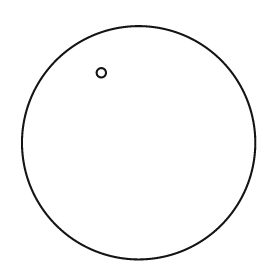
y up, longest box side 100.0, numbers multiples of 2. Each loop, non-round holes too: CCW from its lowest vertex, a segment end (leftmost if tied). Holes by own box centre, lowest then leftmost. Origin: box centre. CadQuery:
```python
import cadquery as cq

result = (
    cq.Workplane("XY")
    .moveTo(0.0, 0.0)
    .circle(50.0)
    .moveTo(-16.0, 30.0)
    .circle(2.0)
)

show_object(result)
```